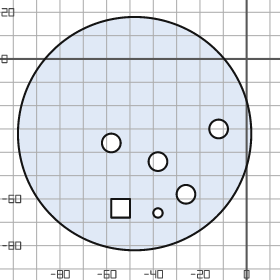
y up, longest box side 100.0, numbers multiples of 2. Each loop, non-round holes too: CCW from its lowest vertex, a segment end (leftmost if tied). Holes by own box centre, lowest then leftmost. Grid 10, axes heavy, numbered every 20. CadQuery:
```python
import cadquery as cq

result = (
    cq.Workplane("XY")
    .moveTo(-48.0, -32.0)
    .circle(50.0)
    .moveTo(-38.0, -66.0)
    .circle(2.0)
    .moveTo(-58.0, -68.0)
    .lineTo(-50.0, -68.0)
    .lineTo(-50.0, -60.0)
    .lineTo(-58.0, -60.0)
    .close()
    .moveTo(-26.0, -58.0)
    .circle(4.0)
    .moveTo(-38.0, -44.0)
    .circle(4.0)
    .moveTo(-58.0, -36.0)
    .circle(4.0)
    .moveTo(-12.0, -30.0)
    .circle(4.0)
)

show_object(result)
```